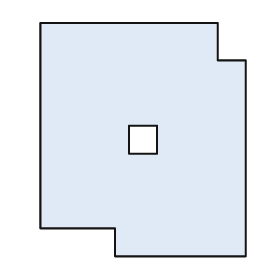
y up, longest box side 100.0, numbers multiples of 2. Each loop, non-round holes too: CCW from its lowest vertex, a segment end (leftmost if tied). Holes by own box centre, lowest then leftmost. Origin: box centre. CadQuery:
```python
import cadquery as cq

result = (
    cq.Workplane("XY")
    .moveTo(-12.0, -50.0)
    .lineTo(44.0, -50.0)
    .lineTo(44.0, 34.0)
    .lineTo(32.0, 34.0)
    .lineTo(32.0, 50.0)
    .lineTo(-44.0, 50.0)
    .lineTo(-44.0, -38.0)
    .lineTo(-12.0, -38.0)
    .close()
    .moveTo(-6.0, -6.0)
    .lineTo(6.0, -6.0)
    .lineTo(6.0, 6.0)
    .lineTo(-6.0, 6.0)
    .close()
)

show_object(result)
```